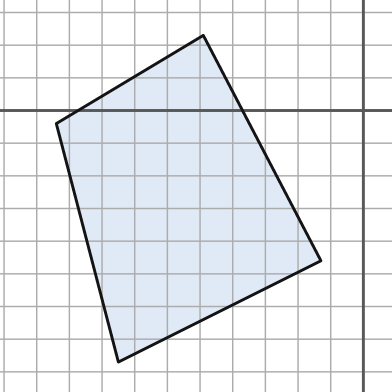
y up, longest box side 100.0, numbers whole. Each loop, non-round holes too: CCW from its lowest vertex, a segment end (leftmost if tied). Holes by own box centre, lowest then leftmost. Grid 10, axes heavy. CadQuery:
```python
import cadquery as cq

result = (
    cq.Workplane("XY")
    .moveTo(-75.0, -77.0)
    .lineTo(-13.0, -46.0)
    .lineTo(-49.0, 23.0)
    .lineTo(-94.0, -4.0)
    .close()
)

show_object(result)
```